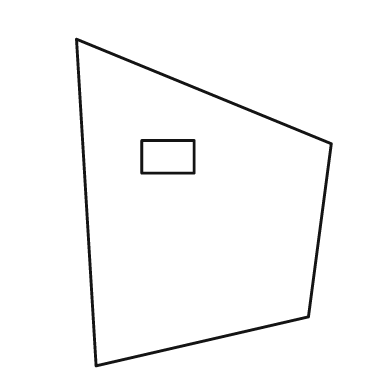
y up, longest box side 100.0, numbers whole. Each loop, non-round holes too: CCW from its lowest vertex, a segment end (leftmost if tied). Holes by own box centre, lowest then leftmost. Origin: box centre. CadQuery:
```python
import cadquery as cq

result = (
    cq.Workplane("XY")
    .moveTo(-33.0, -50.0)
    .lineTo(32.0, -35.0)
    .lineTo(39.0, 18.0)
    .lineTo(-39.0, 50.0)
    .close()
    .moveTo(-19.0, 9.0)
    .lineTo(-3.0, 9.0)
    .lineTo(-3.0, 19.0)
    .lineTo(-19.0, 19.0)
    .close()
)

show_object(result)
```